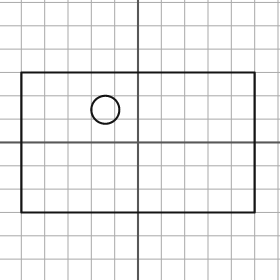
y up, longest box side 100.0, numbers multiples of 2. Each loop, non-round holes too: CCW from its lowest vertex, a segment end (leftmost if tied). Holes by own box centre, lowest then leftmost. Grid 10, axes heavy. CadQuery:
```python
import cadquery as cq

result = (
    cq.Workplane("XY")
    .moveTo(-50.0, -30.0)
    .lineTo(50.0, -30.0)
    .lineTo(50.0, 30.0)
    .lineTo(-50.0, 30.0)
    .close()
    .moveTo(-14.0, 14.0)
    .circle(6.0)
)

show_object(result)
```